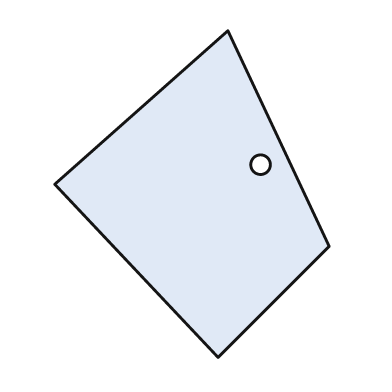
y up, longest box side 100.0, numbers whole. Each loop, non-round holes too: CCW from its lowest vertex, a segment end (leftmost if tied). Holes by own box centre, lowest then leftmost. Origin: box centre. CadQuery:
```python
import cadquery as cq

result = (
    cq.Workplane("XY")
    .moveTo(8.0, -50.0)
    .lineTo(42.0, -16.0)
    .lineTo(11.0, 50.0)
    .lineTo(-42.0, 3.0)
    .close()
    .moveTo(21.0, 9.0)
    .circle(3.0)
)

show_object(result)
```